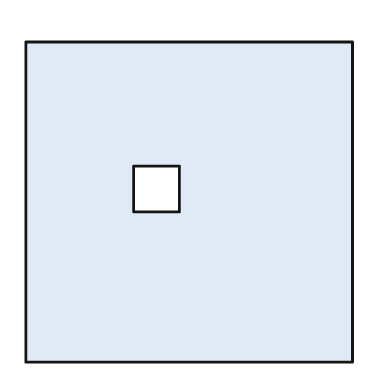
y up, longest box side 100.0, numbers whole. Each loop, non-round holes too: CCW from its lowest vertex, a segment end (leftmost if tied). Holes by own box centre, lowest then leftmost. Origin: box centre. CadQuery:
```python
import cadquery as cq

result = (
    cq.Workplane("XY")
    .moveTo(-50.0, -49.0)
    .lineTo(50.0, -49.0)
    .lineTo(50.0, 49.0)
    .lineTo(-50.0, 49.0)
    .close()
    .moveTo(-17.0, -3.0)
    .lineTo(-3.0, -3.0)
    .lineTo(-3.0, 11.0)
    .lineTo(-17.0, 11.0)
    .close()
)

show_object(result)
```